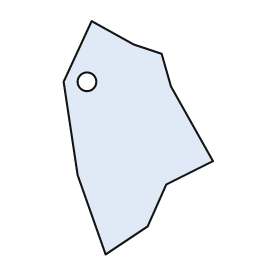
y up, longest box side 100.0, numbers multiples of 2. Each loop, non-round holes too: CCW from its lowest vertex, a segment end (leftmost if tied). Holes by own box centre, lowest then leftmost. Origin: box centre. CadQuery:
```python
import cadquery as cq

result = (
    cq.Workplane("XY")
    .moveTo(-14.0, -50.0)
    .lineTo(4.0, -38.0)
    .lineTo(12.0, -20.0)
    .lineTo(32.0, -10.0)
    .lineTo(14.0, 22.0)
    .lineTo(10.0, 36.0)
    .lineTo(-2.0, 40.0)
    .lineTo(-20.0, 50.0)
    .lineTo(-32.0, 24.0)
    .lineTo(-26.0, -16.0)
    .close()
    .moveTo(-22.0, 24.0)
    .circle(4.0)
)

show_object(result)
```